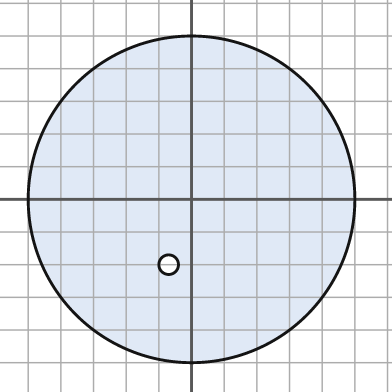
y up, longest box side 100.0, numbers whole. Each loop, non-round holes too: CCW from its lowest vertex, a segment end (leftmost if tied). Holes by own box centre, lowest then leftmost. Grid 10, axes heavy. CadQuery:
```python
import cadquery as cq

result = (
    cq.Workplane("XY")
    .moveTo(0.0, 0.0)
    .circle(50.0)
    .moveTo(-7.0, -20.0)
    .circle(3.0)
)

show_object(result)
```